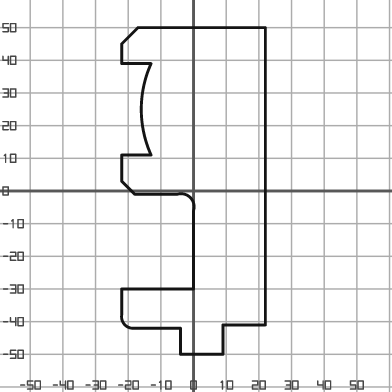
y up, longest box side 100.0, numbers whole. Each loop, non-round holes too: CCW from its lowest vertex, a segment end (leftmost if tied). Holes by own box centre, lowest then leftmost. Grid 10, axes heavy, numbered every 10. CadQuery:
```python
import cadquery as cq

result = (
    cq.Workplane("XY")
    .moveTo(-4.0, -50.0)
    .lineTo(9.0, -50.0)
    .lineTo(9.0, -41.0)
    .lineTo(22.0, -41.0)
    .lineTo(22.0, 50.0)
    .lineTo(-17.0, 50.0)
    .lineTo(-22.0, 45.0)
    .lineTo(-22.0, 39.0)
    .lineTo(-13.0, 39.0)
    .threePointArc((-16.0, 25.0), (-13.0, 11.0))
    .lineTo(-22.0, 11.0)
    .lineTo(-22.0, 3.0)
    .lineTo(-18.0, -1.0)
    .lineTo(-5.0, -1.0)
    .threePointArc((-1.0, -2.0), (0.0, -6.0))
    .lineTo(0.0, -30.0)
    .lineTo(-22.0, -30.0)
    .lineTo(-22.0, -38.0)
    .threePointArc((-21.0, -41.0), (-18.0, -42.0))
    .lineTo(-4.0, -42.0)
    .close()
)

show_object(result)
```